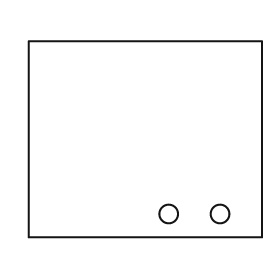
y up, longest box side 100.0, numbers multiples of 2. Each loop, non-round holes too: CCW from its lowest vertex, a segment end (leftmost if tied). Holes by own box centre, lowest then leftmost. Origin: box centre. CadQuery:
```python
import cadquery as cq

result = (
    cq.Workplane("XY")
    .moveTo(-50.0, -42.0)
    .lineTo(50.0, -42.0)
    .lineTo(50.0, 42.0)
    .lineTo(-50.0, 42.0)
    .close()
    .moveTo(10.0, -32.0)
    .circle(4.0)
    .moveTo(32.0, -32.0)
    .circle(4.0)
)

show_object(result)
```